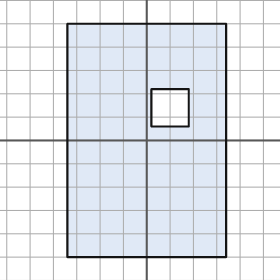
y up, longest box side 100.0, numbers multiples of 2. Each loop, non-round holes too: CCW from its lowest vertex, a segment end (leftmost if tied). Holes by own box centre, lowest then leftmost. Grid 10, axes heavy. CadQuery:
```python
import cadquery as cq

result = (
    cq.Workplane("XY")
    .moveTo(-34.0, -50.0)
    .lineTo(34.0, -50.0)
    .lineTo(34.0, 50.0)
    .lineTo(-34.0, 50.0)
    .close()
    .moveTo(2.0, 6.0)
    .lineTo(18.0, 6.0)
    .lineTo(18.0, 22.0)
    .lineTo(2.0, 22.0)
    .close()
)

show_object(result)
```